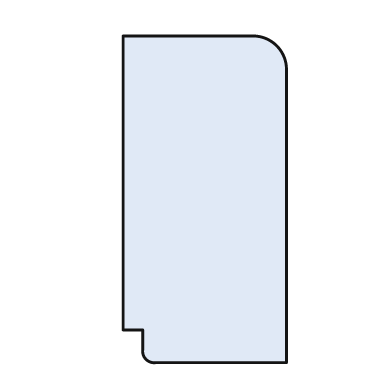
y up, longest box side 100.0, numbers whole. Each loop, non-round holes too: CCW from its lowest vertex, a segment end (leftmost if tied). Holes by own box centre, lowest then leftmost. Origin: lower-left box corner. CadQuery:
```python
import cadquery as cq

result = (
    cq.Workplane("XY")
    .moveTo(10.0, 0.0)
    .lineTo(50.0, 0.0)
    .lineTo(50.0, 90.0)
    .threePointArc((47.0, 97.0), (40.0, 100.0))
    .lineTo(0.0, 100.0)
    .lineTo(0.0, 10.0)
    .lineTo(6.0, 10.0)
    .lineTo(6.0, 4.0)
    .threePointArc((7.0, 1.0), (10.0, 0.0))
    .close()
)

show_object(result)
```